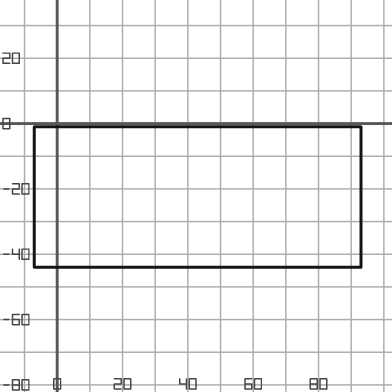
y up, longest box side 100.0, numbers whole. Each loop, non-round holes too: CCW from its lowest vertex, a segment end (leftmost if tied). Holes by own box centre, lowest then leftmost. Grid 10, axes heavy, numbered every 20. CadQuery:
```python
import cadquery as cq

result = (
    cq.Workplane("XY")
    .moveTo(-7.0, -44.0)
    .lineTo(93.0, -44.0)
    .lineTo(93.0, -1.0)
    .lineTo(-7.0, -1.0)
    .close()
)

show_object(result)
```